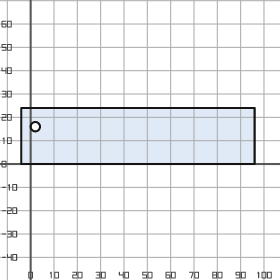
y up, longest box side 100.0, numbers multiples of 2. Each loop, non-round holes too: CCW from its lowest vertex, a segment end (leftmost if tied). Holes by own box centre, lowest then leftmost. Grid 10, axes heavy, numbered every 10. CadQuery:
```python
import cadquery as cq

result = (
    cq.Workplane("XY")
    .moveTo(-4.0, 0.0)
    .lineTo(96.0, 0.0)
    .lineTo(96.0, 24.0)
    .lineTo(-4.0, 24.0)
    .close()
    .moveTo(2.0, 16.0)
    .circle(2.0)
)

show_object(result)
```